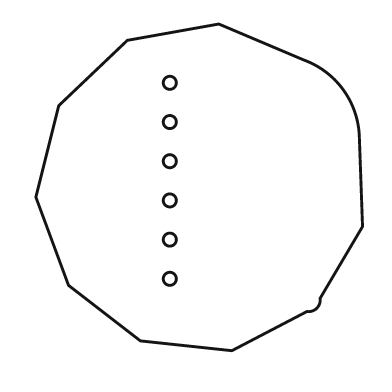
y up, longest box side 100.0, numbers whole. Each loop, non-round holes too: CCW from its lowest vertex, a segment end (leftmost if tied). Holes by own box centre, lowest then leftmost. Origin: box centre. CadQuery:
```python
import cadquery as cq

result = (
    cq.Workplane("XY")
    .moveTo(10.0, -50.0)
    .lineTo(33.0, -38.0)
    .threePointArc((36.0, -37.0), (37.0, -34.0))
    .lineTo(50.0, -12.0)
    .lineTo(49.0, 16.0)
    .threePointArc((44.0, 30.0), (32.0, 39.0))
    .lineTo(6.0, 50.0)
    .lineTo(-22.0, 45.0)
    .lineTo(-43.0, 25.0)
    .lineTo(-50.0, -3.0)
    .lineTo(-40.0, -30.0)
    .lineTo(-18.0, -47.0)
    .close()
    .moveTo(-9.0, -28.0)
    .circle(2.0)
    .moveTo(-9.0, -16.0)
    .circle(2.0)
    .moveTo(-9.0, -4.0)
    .circle(2.0)
    .moveTo(-9.0, 8.0)
    .circle(2.0)
    .moveTo(-9.0, 20.0)
    .circle(2.0)
    .moveTo(-9.0, 32.0)
    .circle(2.0)
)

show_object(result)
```